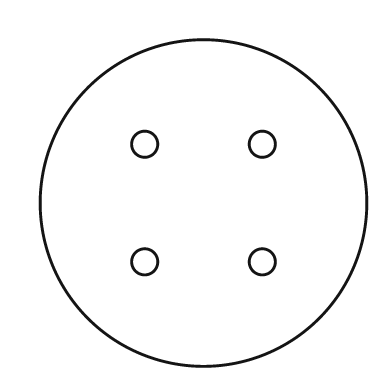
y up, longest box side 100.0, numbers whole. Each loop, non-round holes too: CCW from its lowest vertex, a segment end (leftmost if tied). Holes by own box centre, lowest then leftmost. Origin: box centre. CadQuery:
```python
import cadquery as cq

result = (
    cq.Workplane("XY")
    .moveTo(0.0, 0.0)
    .circle(50.0)
    .moveTo(-18.0, -18.0)
    .circle(4.0)
    .moveTo(18.0, -18.0)
    .circle(4.0)
    .moveTo(-18.0, 18.0)
    .circle(4.0)
    .moveTo(18.0, 18.0)
    .circle(4.0)
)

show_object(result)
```